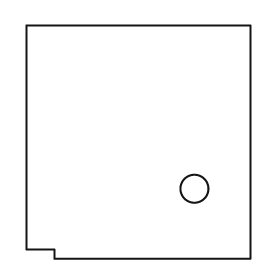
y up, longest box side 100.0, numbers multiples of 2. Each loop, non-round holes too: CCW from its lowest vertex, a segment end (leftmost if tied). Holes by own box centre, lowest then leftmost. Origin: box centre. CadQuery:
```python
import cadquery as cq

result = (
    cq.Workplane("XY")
    .moveTo(-36.0, -50.0)
    .lineTo(48.0, -50.0)
    .lineTo(48.0, 50.0)
    .lineTo(-48.0, 50.0)
    .lineTo(-48.0, -46.0)
    .lineTo(-36.0, -46.0)
    .close()
    .moveTo(24.0, -20.0)
    .circle(6.0)
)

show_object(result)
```